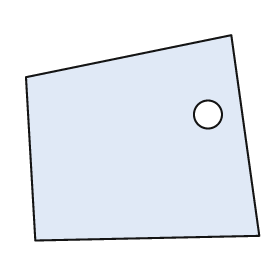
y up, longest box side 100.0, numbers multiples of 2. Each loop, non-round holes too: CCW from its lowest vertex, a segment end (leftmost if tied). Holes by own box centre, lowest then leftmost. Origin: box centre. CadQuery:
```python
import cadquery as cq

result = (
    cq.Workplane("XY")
    .moveTo(-46.0, -44.0)
    .lineTo(50.0, -42.0)
    .lineTo(38.0, 44.0)
    .lineTo(-50.0, 26.0)
    .close()
    .moveTo(28.0, 10.0)
    .circle(6.0)
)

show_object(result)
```